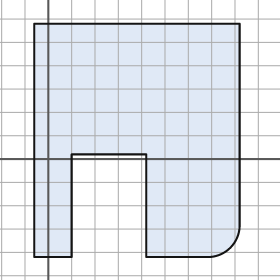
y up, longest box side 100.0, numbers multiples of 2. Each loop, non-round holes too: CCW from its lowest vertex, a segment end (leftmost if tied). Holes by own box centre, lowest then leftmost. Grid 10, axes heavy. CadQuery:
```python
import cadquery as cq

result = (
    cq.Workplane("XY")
    .moveTo(-6.0, -42.0)
    .lineTo(10.0, -42.0)
    .lineTo(10.0, 2.0)
    .lineTo(42.0, 2.0)
    .lineTo(42.0, -42.0)
    .lineTo(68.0, -42.0)
    .threePointArc((78.0, -38.0), (82.0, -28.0))
    .lineTo(82.0, 58.0)
    .lineTo(-6.0, 58.0)
    .close()
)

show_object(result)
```